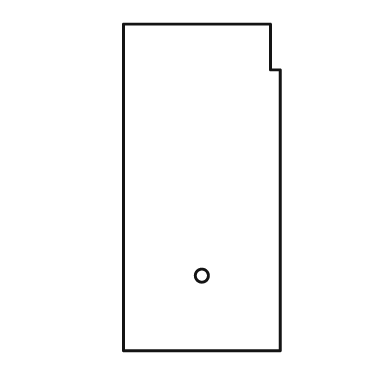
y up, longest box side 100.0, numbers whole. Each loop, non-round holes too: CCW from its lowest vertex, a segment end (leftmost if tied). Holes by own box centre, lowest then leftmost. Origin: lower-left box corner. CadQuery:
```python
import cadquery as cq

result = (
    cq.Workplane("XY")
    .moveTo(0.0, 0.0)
    .lineTo(48.0, 0.0)
    .lineTo(48.0, 86.0)
    .lineTo(45.0, 86.0)
    .lineTo(45.0, 100.0)
    .lineTo(0.0, 100.0)
    .close()
    .moveTo(24.0, 23.0)
    .circle(2.0)
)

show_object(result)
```